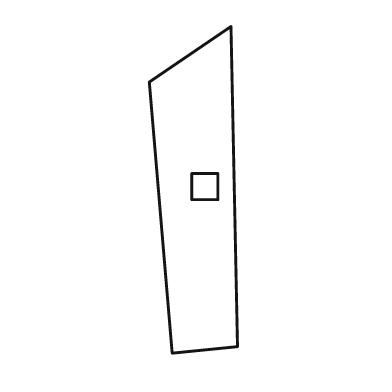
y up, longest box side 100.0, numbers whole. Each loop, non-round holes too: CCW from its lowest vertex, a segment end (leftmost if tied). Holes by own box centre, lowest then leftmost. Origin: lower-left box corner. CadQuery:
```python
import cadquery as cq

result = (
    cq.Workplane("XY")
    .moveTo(7.0, 0.0)
    .lineTo(27.0, 2.0)
    .lineTo(25.0, 100.0)
    .lineTo(0.0, 83.0)
    .close()
    .moveTo(13.0, 47.0)
    .lineTo(21.0, 47.0)
    .lineTo(21.0, 55.0)
    .lineTo(13.0, 55.0)
    .close()
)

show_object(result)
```